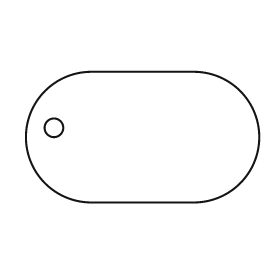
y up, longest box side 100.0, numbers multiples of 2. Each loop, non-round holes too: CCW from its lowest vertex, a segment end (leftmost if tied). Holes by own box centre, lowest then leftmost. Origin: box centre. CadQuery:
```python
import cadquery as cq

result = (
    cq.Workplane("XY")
    .moveTo(-22.0, -28.0)
    .lineTo(22.0, -28.0)
    .threePointArc((50.0, 0.0), (22.0, 28.0))
    .lineTo(-22.0, 28.0)
    .threePointArc((-50.0, 0.0), (-22.0, -28.0))
    .close()
    .moveTo(-38.0, 4.0)
    .circle(4.0)
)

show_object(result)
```